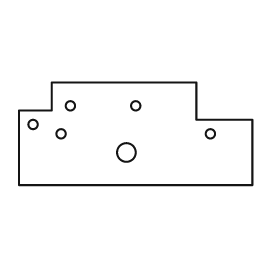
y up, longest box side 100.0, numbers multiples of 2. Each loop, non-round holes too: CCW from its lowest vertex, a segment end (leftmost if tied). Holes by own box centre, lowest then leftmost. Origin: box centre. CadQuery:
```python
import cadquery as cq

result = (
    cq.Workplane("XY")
    .moveTo(-50.0, -22.0)
    .lineTo(50.0, -22.0)
    .lineTo(50.0, 6.0)
    .lineTo(26.0, 6.0)
    .lineTo(26.0, 22.0)
    .lineTo(-36.0, 22.0)
    .lineTo(-36.0, 10.0)
    .lineTo(-50.0, 10.0)
    .close()
    .moveTo(-4.0, -8.0)
    .circle(4.0)
    .moveTo(-32.0, 0.0)
    .circle(2.0)
    .moveTo(32.0, 0.0)
    .circle(2.0)
    .moveTo(-44.0, 4.0)
    .circle(2.0)
    .moveTo(-28.0, 12.0)
    .circle(2.0)
    .moveTo(0.0, 12.0)
    .circle(2.0)
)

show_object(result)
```